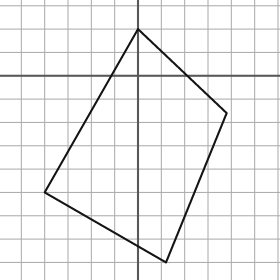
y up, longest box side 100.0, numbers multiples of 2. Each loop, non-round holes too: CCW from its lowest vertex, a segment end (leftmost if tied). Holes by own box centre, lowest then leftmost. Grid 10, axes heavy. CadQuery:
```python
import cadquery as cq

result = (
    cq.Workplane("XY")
    .moveTo(12.0, -80.0)
    .lineTo(38.0, -16.0)
    .lineTo(0.0, 20.0)
    .lineTo(-40.0, -50.0)
    .close()
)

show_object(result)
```